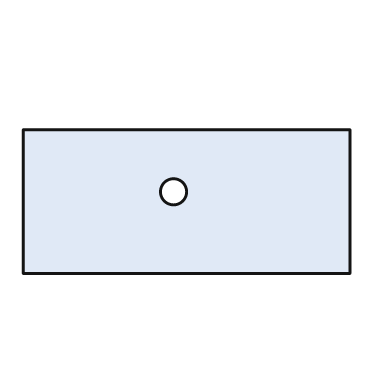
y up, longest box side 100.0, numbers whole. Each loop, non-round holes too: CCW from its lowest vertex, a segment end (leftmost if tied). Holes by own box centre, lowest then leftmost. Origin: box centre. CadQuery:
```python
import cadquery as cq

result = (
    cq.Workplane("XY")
    .moveTo(-50.0, -22.0)
    .lineTo(50.0, -22.0)
    .lineTo(50.0, 22.0)
    .lineTo(-50.0, 22.0)
    .close()
    .moveTo(-4.0, 3.0)
    .circle(4.0)
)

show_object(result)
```